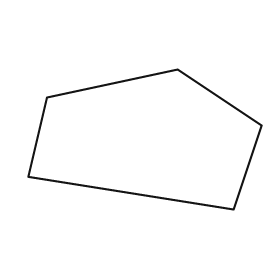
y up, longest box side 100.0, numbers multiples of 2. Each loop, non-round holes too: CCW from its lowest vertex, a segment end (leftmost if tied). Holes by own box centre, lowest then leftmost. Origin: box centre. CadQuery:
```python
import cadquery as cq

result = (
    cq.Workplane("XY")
    .moveTo(38.0, -30.0)
    .lineTo(50.0, 6.0)
    .lineTo(14.0, 30.0)
    .lineTo(-42.0, 18.0)
    .lineTo(-50.0, -16.0)
    .close()
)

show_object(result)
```